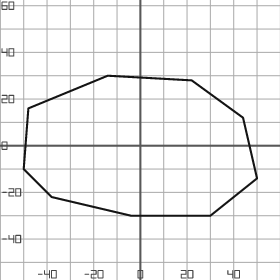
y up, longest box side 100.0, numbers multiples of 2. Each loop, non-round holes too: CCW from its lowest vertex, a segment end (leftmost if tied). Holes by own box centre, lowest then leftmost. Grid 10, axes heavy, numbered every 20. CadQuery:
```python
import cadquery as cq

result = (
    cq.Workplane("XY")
    .moveTo(-4.0, -30.0)
    .lineTo(30.0, -30.0)
    .lineTo(50.0, -14.0)
    .lineTo(44.0, 12.0)
    .lineTo(22.0, 28.0)
    .lineTo(-14.0, 30.0)
    .lineTo(-48.0, 16.0)
    .lineTo(-50.0, -10.0)
    .lineTo(-38.0, -22.0)
    .close()
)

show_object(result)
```